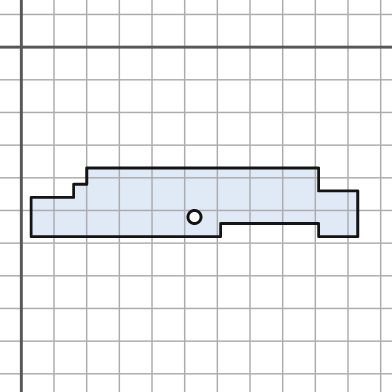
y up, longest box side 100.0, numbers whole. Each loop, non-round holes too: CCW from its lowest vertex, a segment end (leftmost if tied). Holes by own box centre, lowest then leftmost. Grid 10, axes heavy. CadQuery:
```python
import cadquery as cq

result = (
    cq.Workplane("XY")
    .moveTo(3.0, -58.0)
    .lineTo(61.0, -58.0)
    .lineTo(61.0, -54.0)
    .lineTo(91.0, -54.0)
    .lineTo(91.0, -58.0)
    .lineTo(103.0, -58.0)
    .lineTo(103.0, -44.0)
    .lineTo(91.0, -44.0)
    .lineTo(91.0, -37.0)
    .lineTo(20.0, -37.0)
    .lineTo(20.0, -42.0)
    .lineTo(16.0, -42.0)
    .lineTo(16.0, -46.0)
    .lineTo(3.0, -46.0)
    .close()
    .moveTo(53.0, -52.0)
    .circle(2.0)
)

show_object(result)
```